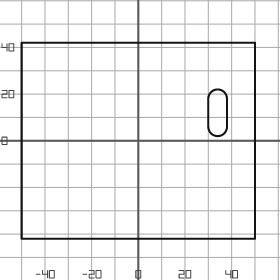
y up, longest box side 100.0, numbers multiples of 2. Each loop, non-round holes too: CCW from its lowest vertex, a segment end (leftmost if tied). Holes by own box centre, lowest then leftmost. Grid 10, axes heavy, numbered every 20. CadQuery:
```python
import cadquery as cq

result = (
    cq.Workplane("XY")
    .moveTo(-50.0, -42.0)
    .lineTo(50.0, -42.0)
    .lineTo(50.0, 42.0)
    .lineTo(-50.0, 42.0)
    .close()
    .moveTo(30.0, 6.0)
    .threePointArc((34.0, 2.0), (38.0, 6.0))
    .lineTo(38.0, 18.0)
    .threePointArc((34.0, 22.0), (30.0, 18.0))
    .close()
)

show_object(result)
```